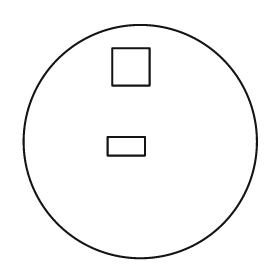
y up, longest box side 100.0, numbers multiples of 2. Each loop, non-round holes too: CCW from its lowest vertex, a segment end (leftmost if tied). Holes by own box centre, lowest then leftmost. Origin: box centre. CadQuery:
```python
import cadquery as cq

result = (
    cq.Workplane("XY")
    .moveTo(0.0, 0.0)
    .circle(50.0)
    .moveTo(-14.0, -6.0)
    .lineTo(2.0, -6.0)
    .lineTo(2.0, 2.0)
    .lineTo(-14.0, 2.0)
    .close()
    .moveTo(-12.0, 24.0)
    .lineTo(4.0, 24.0)
    .lineTo(4.0, 40.0)
    .lineTo(-12.0, 40.0)
    .close()
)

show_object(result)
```